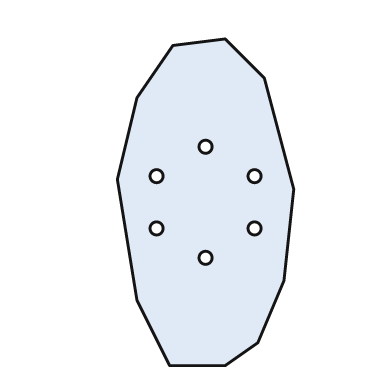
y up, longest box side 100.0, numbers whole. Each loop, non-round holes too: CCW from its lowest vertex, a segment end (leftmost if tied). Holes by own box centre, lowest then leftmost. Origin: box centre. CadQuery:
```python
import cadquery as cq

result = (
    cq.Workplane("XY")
    .moveTo(-11.0, -50.0)
    .lineTo(6.0, -50.0)
    .lineTo(16.0, -43.0)
    .lineTo(24.0, -24.0)
    .lineTo(27.0, 4.0)
    .lineTo(18.0, 38.0)
    .lineTo(6.0, 50.0)
    .lineTo(-10.0, 48.0)
    .lineTo(-21.0, 32.0)
    .lineTo(-27.0, 7.0)
    .lineTo(-21.0, -30.0)
    .close()
    .moveTo(0.0, -17.0)
    .circle(2.0)
    .moveTo(-15.0, -8.0)
    .circle(2.0)
    .moveTo(15.0, -8.0)
    .circle(2.0)
    .moveTo(-15.0, 8.0)
    .circle(2.0)
    .moveTo(15.0, 8.0)
    .circle(2.0)
    .moveTo(0.0, 17.0)
    .circle(2.0)
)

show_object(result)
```